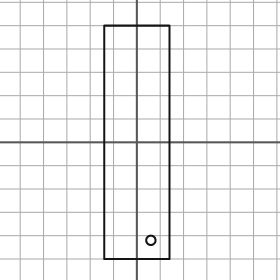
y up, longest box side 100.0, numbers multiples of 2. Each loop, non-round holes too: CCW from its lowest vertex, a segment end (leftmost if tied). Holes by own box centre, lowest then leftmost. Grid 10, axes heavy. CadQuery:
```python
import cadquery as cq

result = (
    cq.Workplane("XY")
    .moveTo(-14.0, -50.0)
    .lineTo(14.0, -50.0)
    .lineTo(14.0, 50.0)
    .lineTo(-14.0, 50.0)
    .close()
    .moveTo(6.0, -42.0)
    .circle(2.0)
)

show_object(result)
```